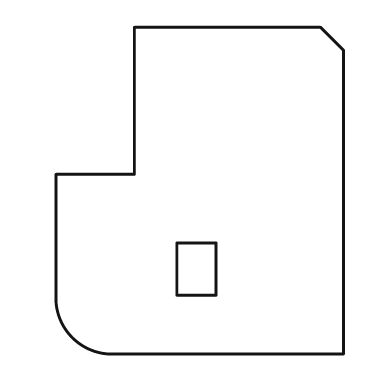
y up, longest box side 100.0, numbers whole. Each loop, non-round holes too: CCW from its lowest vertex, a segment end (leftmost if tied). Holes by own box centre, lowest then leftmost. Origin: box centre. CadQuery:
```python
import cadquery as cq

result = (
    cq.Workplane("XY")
    .moveTo(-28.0, -50.0)
    .lineTo(44.0, -50.0)
    .lineTo(44.0, 43.0)
    .lineTo(37.0, 50.0)
    .lineTo(-20.0, 50.0)
    .lineTo(-20.0, 5.0)
    .lineTo(-44.0, 5.0)
    .lineTo(-44.0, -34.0)
    .threePointArc((-39.0, -45.0), (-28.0, -50.0))
    .close()
    .moveTo(-7.0, -32.0)
    .lineTo(5.0, -32.0)
    .lineTo(5.0, -16.0)
    .lineTo(-7.0, -16.0)
    .close()
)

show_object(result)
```